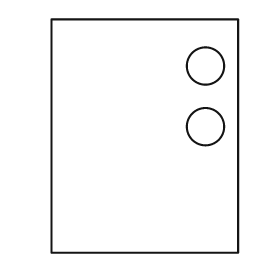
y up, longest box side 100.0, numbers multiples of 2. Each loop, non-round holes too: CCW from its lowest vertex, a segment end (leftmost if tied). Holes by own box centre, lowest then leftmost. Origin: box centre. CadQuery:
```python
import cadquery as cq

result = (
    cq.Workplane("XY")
    .moveTo(-40.0, -50.0)
    .lineTo(40.0, -50.0)
    .lineTo(40.0, 50.0)
    .lineTo(-40.0, 50.0)
    .close()
    .moveTo(26.0, 4.0)
    .circle(8.0)
    .moveTo(26.0, 30.0)
    .circle(8.0)
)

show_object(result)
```